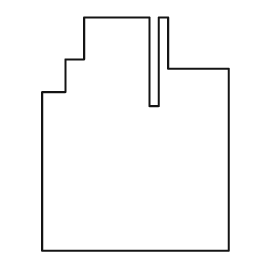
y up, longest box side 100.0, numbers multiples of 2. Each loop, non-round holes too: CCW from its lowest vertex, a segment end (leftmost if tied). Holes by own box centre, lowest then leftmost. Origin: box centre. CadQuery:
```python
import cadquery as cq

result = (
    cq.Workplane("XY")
    .moveTo(-40.0, -50.0)
    .lineTo(40.0, -50.0)
    .lineTo(40.0, 28.0)
    .lineTo(14.0, 28.0)
    .lineTo(14.0, 50.0)
    .lineTo(10.0, 50.0)
    .lineTo(10.0, 12.0)
    .lineTo(6.0, 12.0)
    .lineTo(6.0, 50.0)
    .lineTo(-22.0, 50.0)
    .lineTo(-22.0, 32.0)
    .lineTo(-30.0, 32.0)
    .lineTo(-30.0, 18.0)
    .lineTo(-40.0, 18.0)
    .close()
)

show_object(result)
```